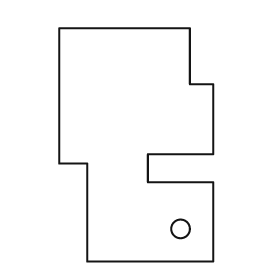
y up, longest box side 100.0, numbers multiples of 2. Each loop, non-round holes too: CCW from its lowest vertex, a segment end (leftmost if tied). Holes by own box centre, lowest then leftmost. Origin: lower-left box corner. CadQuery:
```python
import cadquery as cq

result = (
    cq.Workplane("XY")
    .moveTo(12.0, 0.0)
    .lineTo(66.0, 0.0)
    .lineTo(66.0, 34.0)
    .lineTo(38.0, 34.0)
    .lineTo(38.0, 46.0)
    .lineTo(66.0, 46.0)
    .lineTo(66.0, 76.0)
    .lineTo(56.0, 76.0)
    .lineTo(56.0, 100.0)
    .lineTo(0.0, 100.0)
    .lineTo(0.0, 42.0)
    .lineTo(12.0, 42.0)
    .close()
    .moveTo(52.0, 14.0)
    .circle(4.0)
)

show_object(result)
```